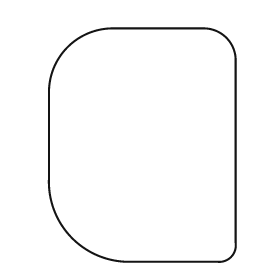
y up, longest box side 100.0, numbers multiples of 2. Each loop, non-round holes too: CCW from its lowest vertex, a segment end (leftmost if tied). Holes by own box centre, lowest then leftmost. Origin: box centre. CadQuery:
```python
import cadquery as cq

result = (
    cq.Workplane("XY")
    .moveTo(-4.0, -50.0)
    .lineTo(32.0, -50.0)
    .threePointArc((38.0, -48.0), (40.0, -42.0))
    .lineTo(40.0, 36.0)
    .threePointArc((36.0, 46.0), (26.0, 50.0))
    .lineTo(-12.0, 50.0)
    .threePointArc((-32.0, 42.0), (-40.0, 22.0))
    .lineTo(-40.0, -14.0)
    .threePointArc((-30.0, -40.0), (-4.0, -50.0))
    .close()
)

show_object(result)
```